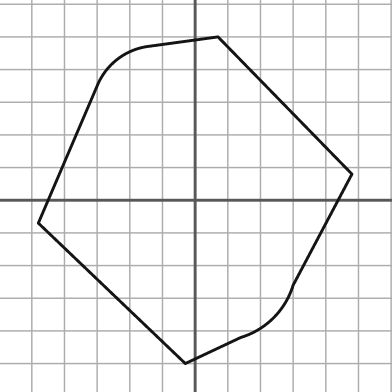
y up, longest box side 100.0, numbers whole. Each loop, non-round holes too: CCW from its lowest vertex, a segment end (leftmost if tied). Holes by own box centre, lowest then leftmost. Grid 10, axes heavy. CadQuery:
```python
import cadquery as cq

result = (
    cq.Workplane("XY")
    .moveTo(-3.0, -50.0)
    .lineTo(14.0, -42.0)
    .threePointArc((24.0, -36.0), (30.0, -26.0))
    .lineTo(48.0, 8.0)
    .lineTo(7.0, 50.0)
    .lineTo(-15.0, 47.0)
    .threePointArc((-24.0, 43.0), (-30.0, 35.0))
    .lineTo(-48.0, -7.0)
    .close()
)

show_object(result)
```